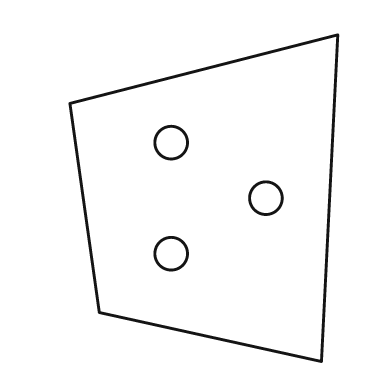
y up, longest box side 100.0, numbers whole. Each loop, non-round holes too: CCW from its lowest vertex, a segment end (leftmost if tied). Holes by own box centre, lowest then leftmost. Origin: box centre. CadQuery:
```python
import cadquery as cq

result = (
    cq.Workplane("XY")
    .moveTo(36.0, -50.0)
    .lineTo(41.0, 50.0)
    .lineTo(-41.0, 29.0)
    .lineTo(-32.0, -35.0)
    .close()
    .moveTo(-10.0, -17.0)
    .circle(5.0)
    .moveTo(19.0, 0.0)
    .circle(5.0)
    .moveTo(-10.0, 17.0)
    .circle(5.0)
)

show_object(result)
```